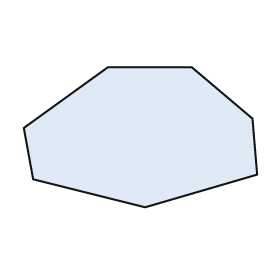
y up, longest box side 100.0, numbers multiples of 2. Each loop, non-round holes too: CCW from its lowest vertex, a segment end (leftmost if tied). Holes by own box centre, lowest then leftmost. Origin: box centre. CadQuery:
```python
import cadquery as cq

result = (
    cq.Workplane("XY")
    .moveTo(2.0, -30.0)
    .lineTo(50.0, -16.0)
    .lineTo(48.0, 8.0)
    .lineTo(22.0, 30.0)
    .lineTo(-14.0, 30.0)
    .lineTo(-50.0, 4.0)
    .lineTo(-46.0, -18.0)
    .close()
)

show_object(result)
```